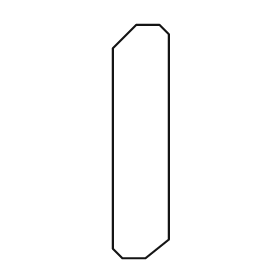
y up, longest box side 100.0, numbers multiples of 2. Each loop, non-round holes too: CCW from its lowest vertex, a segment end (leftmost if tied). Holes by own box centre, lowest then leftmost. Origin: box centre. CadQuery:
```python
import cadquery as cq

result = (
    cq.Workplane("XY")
    .moveTo(-8.0, -50.0)
    .lineTo(2.0, -50.0)
    .lineTo(12.0, -42.0)
    .lineTo(12.0, 46.0)
    .lineTo(8.0, 50.0)
    .lineTo(-2.0, 50.0)
    .lineTo(-12.0, 40.0)
    .lineTo(-12.0, -46.0)
    .close()
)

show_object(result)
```